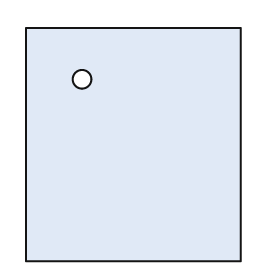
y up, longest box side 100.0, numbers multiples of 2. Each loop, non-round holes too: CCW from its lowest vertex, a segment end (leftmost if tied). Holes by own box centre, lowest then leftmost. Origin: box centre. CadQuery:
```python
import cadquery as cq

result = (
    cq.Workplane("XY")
    .moveTo(-46.0, -50.0)
    .lineTo(46.0, -50.0)
    .lineTo(46.0, 50.0)
    .lineTo(-46.0, 50.0)
    .close()
    .moveTo(-22.0, 28.0)
    .circle(4.0)
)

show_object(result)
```